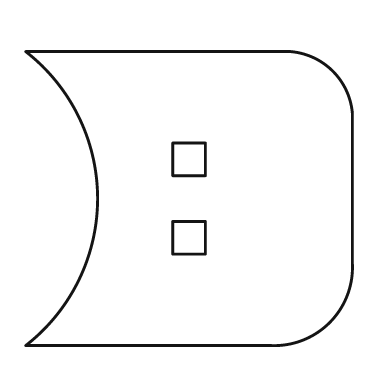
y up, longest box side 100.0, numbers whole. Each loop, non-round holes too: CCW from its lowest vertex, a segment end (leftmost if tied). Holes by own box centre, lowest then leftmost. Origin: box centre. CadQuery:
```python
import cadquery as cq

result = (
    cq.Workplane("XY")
    .moveTo(-50.0, -45.0)
    .lineTo(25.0, -45.0)
    .threePointArc((43.0, -38.0), (50.0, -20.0))
    .lineTo(50.0, 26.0)
    .threePointArc((44.0, 39.0), (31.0, 45.0))
    .lineTo(-50.0, 45.0)
    .threePointArc((-28.0, 0.0), (-50.0, -45.0))
    .close()
    .moveTo(-5.0, -17.0)
    .lineTo(5.0, -17.0)
    .lineTo(5.0, -7.0)
    .lineTo(-5.0, -7.0)
    .close()
    .moveTo(-5.0, 7.0)
    .lineTo(5.0, 7.0)
    .lineTo(5.0, 17.0)
    .lineTo(-5.0, 17.0)
    .close()
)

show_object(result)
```